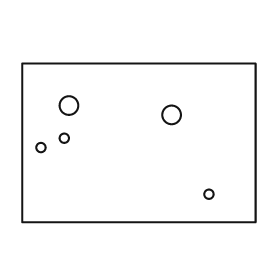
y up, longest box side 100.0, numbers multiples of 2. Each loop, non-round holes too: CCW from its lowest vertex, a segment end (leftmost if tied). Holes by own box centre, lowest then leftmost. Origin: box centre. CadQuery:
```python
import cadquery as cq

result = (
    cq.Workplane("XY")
    .moveTo(-50.0, -34.0)
    .lineTo(50.0, -34.0)
    .lineTo(50.0, 34.0)
    .lineTo(-50.0, 34.0)
    .close()
    .moveTo(30.0, -22.0)
    .circle(2.0)
    .moveTo(-42.0, -2.0)
    .circle(2.0)
    .moveTo(-32.0, 2.0)
    .circle(2.0)
    .moveTo(14.0, 12.0)
    .circle(4.0)
    .moveTo(-30.0, 16.0)
    .circle(4.0)
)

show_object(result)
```